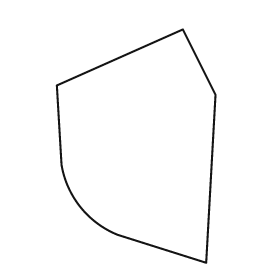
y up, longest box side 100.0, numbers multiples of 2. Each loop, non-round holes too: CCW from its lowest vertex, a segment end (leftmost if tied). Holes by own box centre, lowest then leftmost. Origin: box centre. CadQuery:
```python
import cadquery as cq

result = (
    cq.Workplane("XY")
    .moveTo(30.0, -50.0)
    .lineTo(34.0, 22.0)
    .lineTo(20.0, 50.0)
    .lineTo(-34.0, 26.0)
    .lineTo(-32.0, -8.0)
    .threePointArc((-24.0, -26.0), (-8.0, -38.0))
    .close()
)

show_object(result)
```